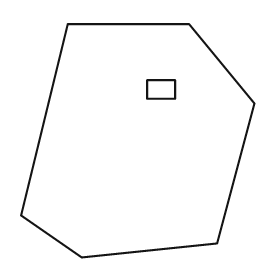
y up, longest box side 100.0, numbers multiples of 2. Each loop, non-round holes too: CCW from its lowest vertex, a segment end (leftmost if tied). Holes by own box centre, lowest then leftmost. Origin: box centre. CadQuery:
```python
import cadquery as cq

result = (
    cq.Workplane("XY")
    .moveTo(-24.0, -50.0)
    .lineTo(34.0, -44.0)
    .lineTo(50.0, 16.0)
    .lineTo(22.0, 50.0)
    .lineTo(-30.0, 50.0)
    .lineTo(-50.0, -32.0)
    .close()
    .moveTo(4.0, 18.0)
    .lineTo(16.0, 18.0)
    .lineTo(16.0, 26.0)
    .lineTo(4.0, 26.0)
    .close()
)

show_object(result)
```